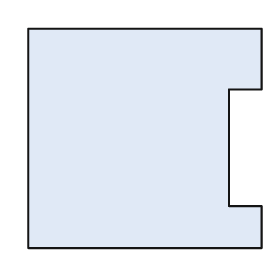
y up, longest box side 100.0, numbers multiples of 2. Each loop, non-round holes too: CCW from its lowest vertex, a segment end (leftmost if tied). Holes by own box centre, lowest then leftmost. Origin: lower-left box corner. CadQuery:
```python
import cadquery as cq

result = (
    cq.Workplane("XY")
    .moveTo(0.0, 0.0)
    .lineTo(100.0, 0.0)
    .lineTo(100.0, 18.0)
    .lineTo(86.0, 18.0)
    .lineTo(86.0, 68.0)
    .lineTo(100.0, 68.0)
    .lineTo(100.0, 94.0)
    .lineTo(0.0, 94.0)
    .close()
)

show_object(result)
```